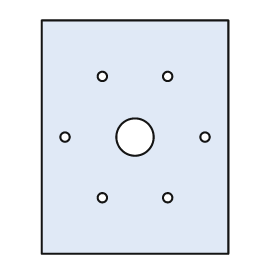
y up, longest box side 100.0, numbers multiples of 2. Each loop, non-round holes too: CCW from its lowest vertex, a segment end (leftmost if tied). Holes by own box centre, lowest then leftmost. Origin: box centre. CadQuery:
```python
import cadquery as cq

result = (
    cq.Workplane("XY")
    .moveTo(-40.0, -50.0)
    .lineTo(40.0, -50.0)
    .lineTo(40.0, 50.0)
    .lineTo(-40.0, 50.0)
    .close()
    .moveTo(-14.0, -26.0)
    .circle(2.0)
    .moveTo(14.0, -26.0)
    .circle(2.0)
    .moveTo(-30.0, 0.0)
    .circle(2.0)
    .moveTo(0.0, 0.0)
    .circle(8.0)
    .moveTo(30.0, 0.0)
    .circle(2.0)
    .moveTo(-14.0, 26.0)
    .circle(2.0)
    .moveTo(14.0, 26.0)
    .circle(2.0)
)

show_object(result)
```